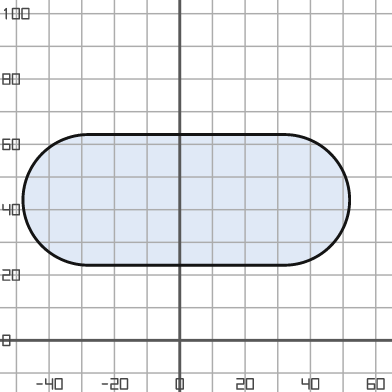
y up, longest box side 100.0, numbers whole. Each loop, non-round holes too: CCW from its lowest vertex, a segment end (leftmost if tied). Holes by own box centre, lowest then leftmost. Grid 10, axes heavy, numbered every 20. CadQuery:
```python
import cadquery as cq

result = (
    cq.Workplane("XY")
    .moveTo(-28.0, 23.0)
    .lineTo(32.0, 23.0)
    .threePointArc((52.0, 43.0), (32.0, 63.0))
    .lineTo(-28.0, 63.0)
    .threePointArc((-48.0, 43.0), (-28.0, 23.0))
    .close()
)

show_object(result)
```